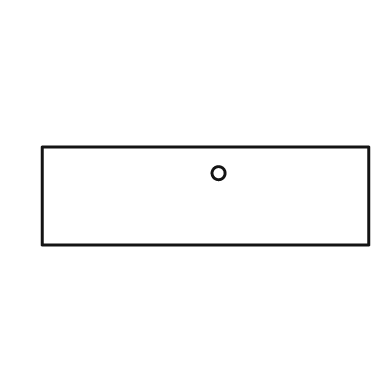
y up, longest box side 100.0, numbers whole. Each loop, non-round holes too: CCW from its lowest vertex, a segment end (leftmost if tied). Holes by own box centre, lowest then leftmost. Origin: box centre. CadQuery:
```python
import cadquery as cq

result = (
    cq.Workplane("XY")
    .moveTo(-50.0, -15.0)
    .lineTo(50.0, -15.0)
    .lineTo(50.0, 15.0)
    .lineTo(-50.0, 15.0)
    .close()
    .moveTo(4.0, 7.0)
    .circle(2.0)
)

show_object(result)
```